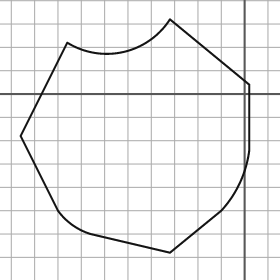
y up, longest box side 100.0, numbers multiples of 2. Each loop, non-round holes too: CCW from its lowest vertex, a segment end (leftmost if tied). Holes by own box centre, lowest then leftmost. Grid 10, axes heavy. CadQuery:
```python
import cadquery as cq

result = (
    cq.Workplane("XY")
    .moveTo(-32.0, -68.0)
    .lineTo(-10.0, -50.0)
    .threePointArc((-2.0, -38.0), (2.0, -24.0))
    .lineTo(2.0, 4.0)
    .lineTo(-32.0, 32.0)
    .threePointArc((-52.0, 18.0), (-76.0, 22.0))
    .lineTo(-96.0, -18.0)
    .lineTo(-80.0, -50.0)
    .threePointArc((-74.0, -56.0), (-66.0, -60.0))
    .close()
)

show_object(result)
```